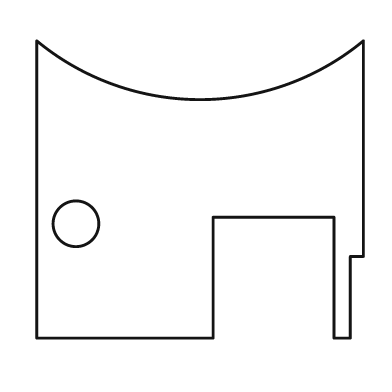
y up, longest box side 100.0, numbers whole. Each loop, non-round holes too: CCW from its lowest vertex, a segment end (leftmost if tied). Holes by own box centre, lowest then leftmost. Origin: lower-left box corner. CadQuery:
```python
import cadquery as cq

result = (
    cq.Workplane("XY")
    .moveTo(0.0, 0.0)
    .lineTo(54.0, 0.0)
    .lineTo(54.0, 37.0)
    .lineTo(91.0, 37.0)
    .lineTo(91.0, 0.0)
    .lineTo(96.0, 0.0)
    .lineTo(96.0, 25.0)
    .lineTo(100.0, 25.0)
    .lineTo(100.0, 91.0)
    .threePointArc((50.0, 73.0), (0.0, 91.0))
    .close()
    .moveTo(12.0, 35.0)
    .circle(7.0)
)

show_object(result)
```